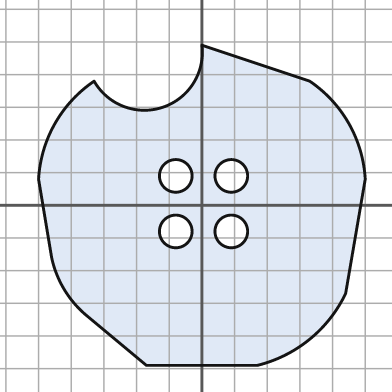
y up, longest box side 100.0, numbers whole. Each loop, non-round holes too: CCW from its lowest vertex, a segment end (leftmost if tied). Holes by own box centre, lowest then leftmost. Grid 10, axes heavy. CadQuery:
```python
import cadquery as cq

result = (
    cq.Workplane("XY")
    .moveTo(-17.0, -49.0)
    .lineTo(17.0, -49.0)
    .threePointArc((33.0, -41.0), (44.0, -27.0))
    .lineTo(50.0, 8.0)
    .threePointArc((45.0, 25.0), (33.0, 38.0))
    .lineTo(0.0, 49.0)
    .threePointArc((-12.0, 30.0), (-33.0, 38.0))
    .threePointArc((-45.0, 25.0), (-50.0, 8.0))
    .lineTo(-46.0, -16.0)
    .threePointArc((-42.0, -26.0), (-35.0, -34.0))
    .close()
    .moveTo(-8.0, -8.0)
    .circle(5.0)
    .moveTo(9.0, -8.0)
    .circle(5.0)
    .moveTo(-8.0, 9.0)
    .circle(5.0)
    .moveTo(9.0, 9.0)
    .circle(5.0)
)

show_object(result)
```